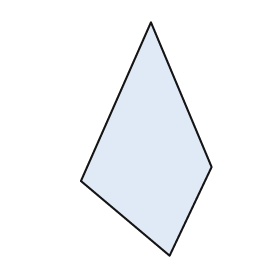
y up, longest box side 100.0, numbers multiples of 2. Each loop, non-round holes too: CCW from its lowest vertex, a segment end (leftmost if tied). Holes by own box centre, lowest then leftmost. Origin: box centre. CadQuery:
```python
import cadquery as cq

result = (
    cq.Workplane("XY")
    .moveTo(10.0, -50.0)
    .lineTo(28.0, -12.0)
    .lineTo(2.0, 50.0)
    .lineTo(-28.0, -18.0)
    .close()
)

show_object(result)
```